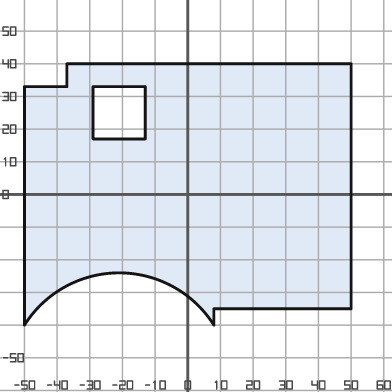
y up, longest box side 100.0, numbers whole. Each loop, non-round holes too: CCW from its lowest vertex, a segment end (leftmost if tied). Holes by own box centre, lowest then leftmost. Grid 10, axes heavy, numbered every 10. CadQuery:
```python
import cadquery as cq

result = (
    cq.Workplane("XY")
    .moveTo(-50.0, -40.0)
    .threePointArc((-21.0, -24.0), (8.0, -40.0))
    .lineTo(8.0, -35.0)
    .lineTo(50.0, -35.0)
    .lineTo(50.0, 40.0)
    .lineTo(-37.0, 40.0)
    .lineTo(-37.0, 33.0)
    .lineTo(-50.0, 33.0)
    .close()
    .moveTo(-29.0, 17.0)
    .lineTo(-13.0, 17.0)
    .lineTo(-13.0, 33.0)
    .lineTo(-29.0, 33.0)
    .close()
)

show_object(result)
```